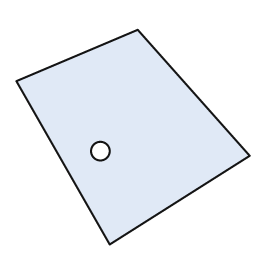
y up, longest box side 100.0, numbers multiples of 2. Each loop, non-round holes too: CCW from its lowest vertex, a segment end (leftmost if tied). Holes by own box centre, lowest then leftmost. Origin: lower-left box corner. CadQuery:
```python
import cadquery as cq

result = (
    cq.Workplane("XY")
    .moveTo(40.0, 0.0)
    .lineTo(100.0, 38.0)
    .lineTo(52.0, 92.0)
    .lineTo(0.0, 70.0)
    .close()
    .moveTo(36.0, 40.0)
    .circle(4.0)
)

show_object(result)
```